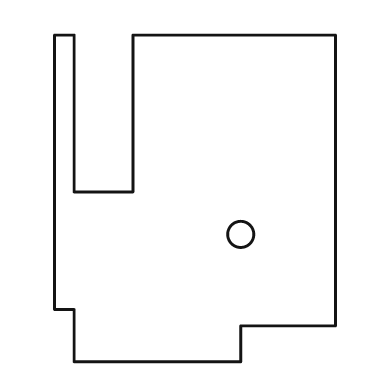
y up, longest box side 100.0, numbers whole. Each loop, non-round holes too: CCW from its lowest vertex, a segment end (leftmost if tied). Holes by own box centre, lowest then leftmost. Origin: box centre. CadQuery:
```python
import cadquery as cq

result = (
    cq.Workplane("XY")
    .moveTo(-37.0, -50.0)
    .lineTo(14.0, -50.0)
    .lineTo(14.0, -39.0)
    .lineTo(43.0, -39.0)
    .lineTo(43.0, 50.0)
    .lineTo(-19.0, 50.0)
    .lineTo(-19.0, 2.0)
    .lineTo(-37.0, 2.0)
    .lineTo(-37.0, 50.0)
    .lineTo(-43.0, 50.0)
    .lineTo(-43.0, -34.0)
    .lineTo(-37.0, -34.0)
    .close()
    .moveTo(14.0, -11.0)
    .circle(4.0)
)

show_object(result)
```